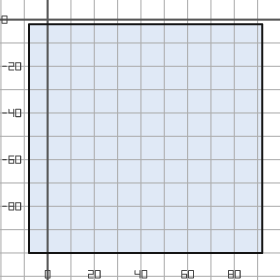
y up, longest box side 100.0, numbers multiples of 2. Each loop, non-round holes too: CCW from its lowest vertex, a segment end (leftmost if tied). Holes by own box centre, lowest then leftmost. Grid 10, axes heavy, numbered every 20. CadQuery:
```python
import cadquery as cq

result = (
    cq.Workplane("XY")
    .moveTo(-8.0, -100.0)
    .lineTo(92.0, -100.0)
    .lineTo(92.0, -2.0)
    .lineTo(-8.0, -2.0)
    .close()
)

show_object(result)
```